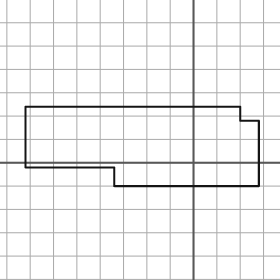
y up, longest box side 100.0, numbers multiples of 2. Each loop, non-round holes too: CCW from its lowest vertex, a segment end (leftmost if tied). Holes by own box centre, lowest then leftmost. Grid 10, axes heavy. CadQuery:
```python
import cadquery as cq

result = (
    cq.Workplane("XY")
    .moveTo(-34.0, -10.0)
    .lineTo(28.0, -10.0)
    .lineTo(28.0, 18.0)
    .lineTo(20.0, 18.0)
    .lineTo(20.0, 24.0)
    .lineTo(-72.0, 24.0)
    .lineTo(-72.0, -2.0)
    .lineTo(-34.0, -2.0)
    .close()
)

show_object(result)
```